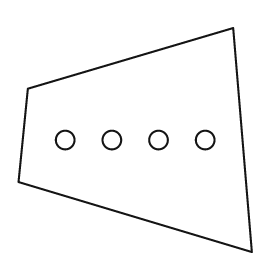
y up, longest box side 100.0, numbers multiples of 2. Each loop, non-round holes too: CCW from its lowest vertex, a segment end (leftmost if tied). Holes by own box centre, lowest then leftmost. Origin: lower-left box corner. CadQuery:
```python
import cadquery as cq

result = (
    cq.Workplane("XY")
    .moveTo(100.0, 0.0)
    .lineTo(92.0, 96.0)
    .lineTo(4.0, 70.0)
    .lineTo(0.0, 30.0)
    .close()
    .moveTo(20.0, 48.0)
    .circle(4.0)
    .moveTo(40.0, 48.0)
    .circle(4.0)
    .moveTo(60.0, 48.0)
    .circle(4.0)
    .moveTo(80.0, 48.0)
    .circle(4.0)
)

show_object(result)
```